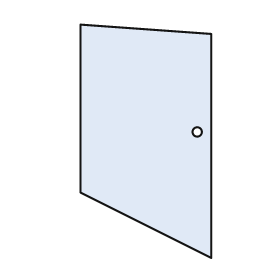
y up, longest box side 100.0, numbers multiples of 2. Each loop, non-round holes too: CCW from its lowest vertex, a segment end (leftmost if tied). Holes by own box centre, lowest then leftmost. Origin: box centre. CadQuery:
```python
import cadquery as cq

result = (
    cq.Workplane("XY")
    .moveTo(28.0, -50.0)
    .lineTo(28.0, 46.0)
    .lineTo(-28.0, 50.0)
    .lineTo(-28.0, -22.0)
    .close()
    .moveTo(22.0, 4.0)
    .circle(2.0)
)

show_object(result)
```